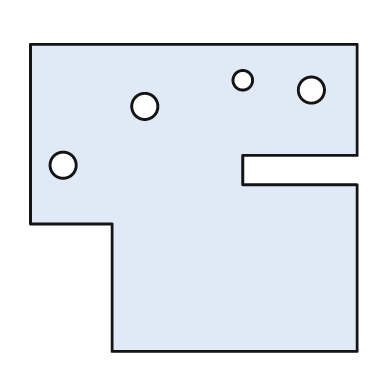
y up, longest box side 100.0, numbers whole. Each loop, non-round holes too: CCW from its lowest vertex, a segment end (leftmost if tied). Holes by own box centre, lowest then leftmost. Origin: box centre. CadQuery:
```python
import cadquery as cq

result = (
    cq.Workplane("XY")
    .moveTo(-25.0, -47.0)
    .lineTo(50.0, -47.0)
    .lineTo(50.0, 4.0)
    .lineTo(15.0, 4.0)
    .lineTo(15.0, 13.0)
    .lineTo(50.0, 13.0)
    .lineTo(50.0, 47.0)
    .lineTo(-50.0, 47.0)
    .lineTo(-50.0, -8.0)
    .lineTo(-25.0, -8.0)
    .close()
    .moveTo(-40.0, 10.0)
    .circle(4.0)
    .moveTo(-15.0, 28.0)
    .circle(4.0)
    .moveTo(36.0, 33.0)
    .circle(4.0)
    .moveTo(15.0, 36.0)
    .circle(3.0)
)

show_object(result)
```